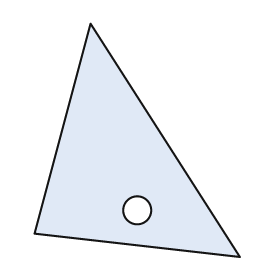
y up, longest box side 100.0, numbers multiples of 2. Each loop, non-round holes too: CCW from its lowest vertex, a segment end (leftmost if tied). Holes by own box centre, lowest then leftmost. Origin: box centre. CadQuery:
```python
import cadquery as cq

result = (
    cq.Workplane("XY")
    .moveTo(44.0, -50.0)
    .lineTo(-20.0, 50.0)
    .lineTo(-44.0, -40.0)
    .close()
    .moveTo(0.0, -30.0)
    .circle(6.0)
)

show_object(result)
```